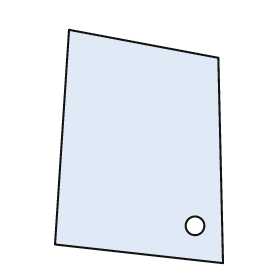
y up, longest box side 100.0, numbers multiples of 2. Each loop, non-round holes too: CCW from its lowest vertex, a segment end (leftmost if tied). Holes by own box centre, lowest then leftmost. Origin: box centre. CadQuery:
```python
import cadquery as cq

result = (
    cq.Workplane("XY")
    .moveTo(36.0, -50.0)
    .lineTo(34.0, 38.0)
    .lineTo(-30.0, 50.0)
    .lineTo(-36.0, -42.0)
    .close()
    .moveTo(24.0, -34.0)
    .circle(4.0)
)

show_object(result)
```